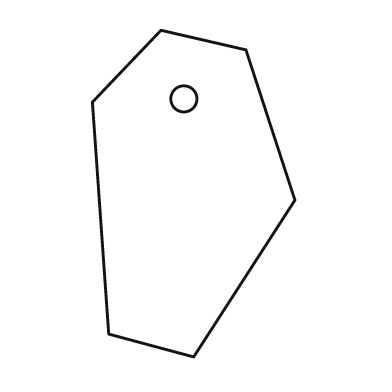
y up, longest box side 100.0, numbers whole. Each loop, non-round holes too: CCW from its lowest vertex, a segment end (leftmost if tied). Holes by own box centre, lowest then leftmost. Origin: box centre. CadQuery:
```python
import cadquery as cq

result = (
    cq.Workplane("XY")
    .moveTo(0.0, -50.0)
    .lineTo(31.0, -2.0)
    .lineTo(16.0, 44.0)
    .lineTo(-10.0, 50.0)
    .lineTo(-31.0, 28.0)
    .lineTo(-26.0, -43.0)
    .close()
    .moveTo(-3.0, 29.0)
    .circle(4.0)
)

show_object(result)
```